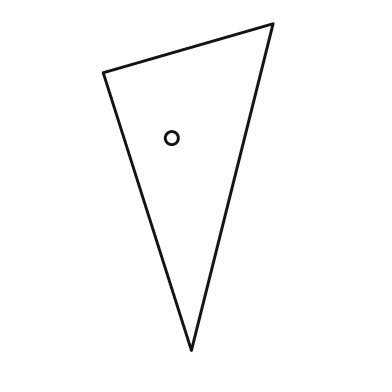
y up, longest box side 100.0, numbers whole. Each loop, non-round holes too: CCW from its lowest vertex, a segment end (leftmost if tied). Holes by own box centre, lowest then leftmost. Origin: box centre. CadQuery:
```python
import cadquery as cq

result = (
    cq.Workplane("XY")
    .moveTo(1.0, -50.0)
    .lineTo(26.0, 50.0)
    .lineTo(-26.0, 35.0)
    .close()
    .moveTo(-5.0, 15.0)
    .circle(2.0)
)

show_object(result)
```